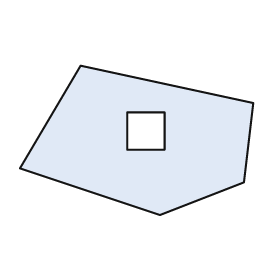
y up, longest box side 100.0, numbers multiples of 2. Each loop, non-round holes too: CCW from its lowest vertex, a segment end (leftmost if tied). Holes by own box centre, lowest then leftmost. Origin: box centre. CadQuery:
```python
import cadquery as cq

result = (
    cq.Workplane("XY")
    .moveTo(10.0, -32.0)
    .lineTo(46.0, -18.0)
    .lineTo(50.0, 16.0)
    .lineTo(-24.0, 32.0)
    .lineTo(-50.0, -12.0)
    .close()
    .moveTo(-4.0, -4.0)
    .lineTo(12.0, -4.0)
    .lineTo(12.0, 12.0)
    .lineTo(-4.0, 12.0)
    .close()
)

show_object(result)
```